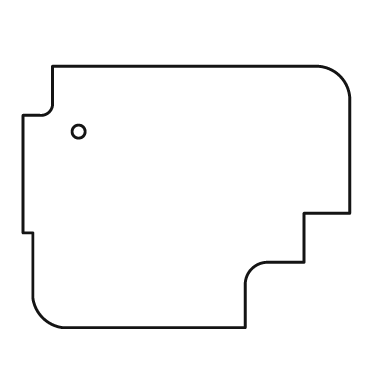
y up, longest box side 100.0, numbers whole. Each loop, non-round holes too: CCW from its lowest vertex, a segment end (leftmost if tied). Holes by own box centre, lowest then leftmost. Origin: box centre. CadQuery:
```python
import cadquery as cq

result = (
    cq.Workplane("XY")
    .moveTo(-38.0, -40.0)
    .lineTo(18.0, -40.0)
    .lineTo(18.0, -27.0)
    .threePointArc((20.0, -22.0), (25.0, -20.0))
    .lineTo(36.0, -20.0)
    .lineTo(36.0, -5.0)
    .lineTo(50.0, -5.0)
    .lineTo(50.0, 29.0)
    .threePointArc((47.0, 37.0), (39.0, 40.0))
    .lineTo(-41.0, 40.0)
    .lineTo(-41.0, 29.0)
    .threePointArc((-42.0, 26.0), (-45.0, 25.0))
    .lineTo(-50.0, 25.0)
    .lineTo(-50.0, -11.0)
    .lineTo(-47.0, -11.0)
    .lineTo(-47.0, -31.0)
    .threePointArc((-44.0, -37.0), (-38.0, -40.0))
    .close()
    .moveTo(-33.0, 20.0)
    .circle(2.0)
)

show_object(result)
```